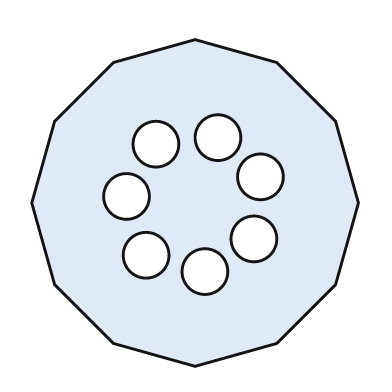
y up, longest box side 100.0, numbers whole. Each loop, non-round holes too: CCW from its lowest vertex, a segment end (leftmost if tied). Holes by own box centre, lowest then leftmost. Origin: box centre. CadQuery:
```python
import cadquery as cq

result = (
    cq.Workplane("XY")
    .moveTo(0.0, -50.0)
    .lineTo(25.0, -43.0)
    .lineTo(43.0, -25.0)
    .lineTo(50.0, 0.0)
    .lineTo(43.0, 25.0)
    .lineTo(25.0, 43.0)
    .lineTo(0.0, 50.0)
    .lineTo(-25.0, 43.0)
    .lineTo(-43.0, 25.0)
    .lineTo(-50.0, 0.0)
    .lineTo(-43.0, -25.0)
    .lineTo(-25.0, -43.0)
    .close()
    .moveTo(3.0, -21.0)
    .circle(7.0)
    .moveTo(-15.0, -16.0)
    .circle(7.0)
    .moveTo(18.0, -11.0)
    .circle(7.0)
    .moveTo(-21.0, 2.0)
    .circle(7.0)
    .moveTo(20.0, 8.0)
    .circle(7.0)
    .moveTo(-12.0, 18.0)
    .circle(7.0)
    .moveTo(7.0, 20.0)
    .circle(7.0)
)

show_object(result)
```